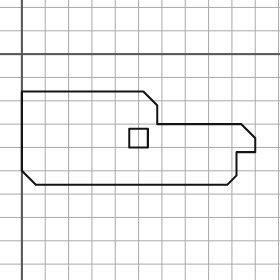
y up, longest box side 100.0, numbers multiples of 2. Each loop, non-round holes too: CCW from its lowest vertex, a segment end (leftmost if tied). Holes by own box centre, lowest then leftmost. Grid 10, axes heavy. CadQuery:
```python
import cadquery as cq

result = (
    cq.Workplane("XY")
    .moveTo(6.0, -56.0)
    .lineTo(88.0, -56.0)
    .lineTo(92.0, -52.0)
    .lineTo(92.0, -42.0)
    .lineTo(100.0, -42.0)
    .lineTo(100.0, -36.0)
    .lineTo(94.0, -30.0)
    .lineTo(58.0, -30.0)
    .lineTo(58.0, -22.0)
    .lineTo(52.0, -16.0)
    .lineTo(0.0, -16.0)
    .lineTo(0.0, -50.0)
    .close()
    .moveTo(46.0, -40.0)
    .lineTo(54.0, -40.0)
    .lineTo(54.0, -32.0)
    .lineTo(46.0, -32.0)
    .close()
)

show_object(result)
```